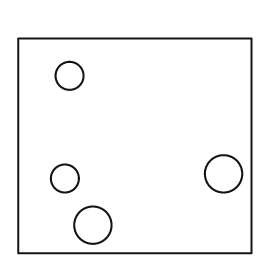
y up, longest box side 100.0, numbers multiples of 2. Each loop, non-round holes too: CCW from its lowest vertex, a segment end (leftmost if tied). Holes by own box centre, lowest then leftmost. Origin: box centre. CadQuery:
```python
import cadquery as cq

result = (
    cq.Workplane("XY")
    .moveTo(-50.0, -46.0)
    .lineTo(50.0, -46.0)
    .lineTo(50.0, 46.0)
    .lineTo(-50.0, 46.0)
    .close()
    .moveTo(-18.0, -34.0)
    .circle(8.0)
    .moveTo(-30.0, -14.0)
    .circle(6.0)
    .moveTo(38.0, -12.0)
    .circle(8.0)
    .moveTo(-28.0, 30.0)
    .circle(6.0)
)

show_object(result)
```